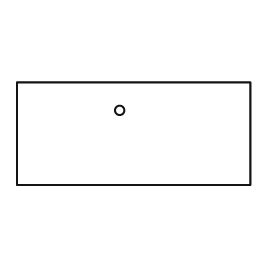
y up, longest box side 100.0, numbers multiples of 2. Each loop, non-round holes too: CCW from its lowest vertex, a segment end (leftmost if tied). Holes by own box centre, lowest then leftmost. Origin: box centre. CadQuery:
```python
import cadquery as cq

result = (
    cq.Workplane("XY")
    .moveTo(-50.0, -22.0)
    .lineTo(50.0, -22.0)
    .lineTo(50.0, 22.0)
    .lineTo(-50.0, 22.0)
    .close()
    .moveTo(-6.0, 10.0)
    .circle(2.0)
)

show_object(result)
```